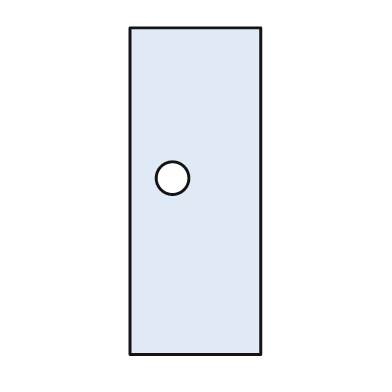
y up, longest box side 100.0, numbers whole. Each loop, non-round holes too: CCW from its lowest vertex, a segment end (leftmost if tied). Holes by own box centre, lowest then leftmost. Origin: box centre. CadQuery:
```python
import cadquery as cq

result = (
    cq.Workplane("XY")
    .moveTo(-20.0, -50.0)
    .lineTo(20.0, -50.0)
    .lineTo(20.0, 50.0)
    .lineTo(-20.0, 50.0)
    .close()
    .moveTo(-7.0, 4.0)
    .circle(5.0)
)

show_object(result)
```